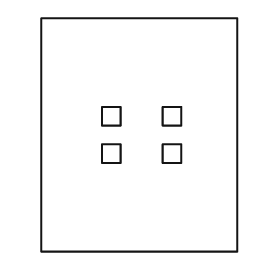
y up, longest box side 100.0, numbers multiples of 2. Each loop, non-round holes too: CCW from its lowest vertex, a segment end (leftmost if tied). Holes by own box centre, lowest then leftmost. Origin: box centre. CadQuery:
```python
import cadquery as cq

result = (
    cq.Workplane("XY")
    .moveTo(-42.0, -50.0)
    .lineTo(42.0, -50.0)
    .lineTo(42.0, 50.0)
    .lineTo(-42.0, 50.0)
    .close()
    .moveTo(-16.0, -12.0)
    .lineTo(-8.0, -12.0)
    .lineTo(-8.0, -4.0)
    .lineTo(-16.0, -4.0)
    .close()
    .moveTo(10.0, -12.0)
    .lineTo(18.0, -12.0)
    .lineTo(18.0, -4.0)
    .lineTo(10.0, -4.0)
    .close()
    .moveTo(-16.0, 4.0)
    .lineTo(-8.0, 4.0)
    .lineTo(-8.0, 12.0)
    .lineTo(-16.0, 12.0)
    .close()
    .moveTo(10.0, 4.0)
    .lineTo(18.0, 4.0)
    .lineTo(18.0, 12.0)
    .lineTo(10.0, 12.0)
    .close()
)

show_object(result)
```